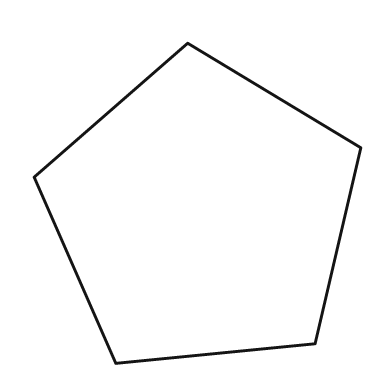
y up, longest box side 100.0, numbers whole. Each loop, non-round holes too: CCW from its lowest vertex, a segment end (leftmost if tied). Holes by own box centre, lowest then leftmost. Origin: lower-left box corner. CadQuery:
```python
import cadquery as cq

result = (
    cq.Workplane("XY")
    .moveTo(25.0, 0.0)
    .lineTo(86.0, 6.0)
    .lineTo(100.0, 66.0)
    .lineTo(47.0, 98.0)
    .lineTo(0.0, 57.0)
    .close()
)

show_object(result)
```